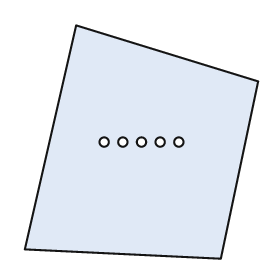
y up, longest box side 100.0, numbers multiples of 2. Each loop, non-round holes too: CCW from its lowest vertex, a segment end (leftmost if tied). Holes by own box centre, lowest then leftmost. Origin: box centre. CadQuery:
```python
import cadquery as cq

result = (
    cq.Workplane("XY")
    .moveTo(34.0, -50.0)
    .lineTo(50.0, 26.0)
    .lineTo(-28.0, 50.0)
    .lineTo(-50.0, -46.0)
    .close()
    .moveTo(-16.0, 0.0)
    .circle(2.0)
    .moveTo(-8.0, 0.0)
    .circle(2.0)
    .moveTo(0.0, 0.0)
    .circle(2.0)
    .moveTo(8.0, 0.0)
    .circle(2.0)
    .moveTo(16.0, 0.0)
    .circle(2.0)
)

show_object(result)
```